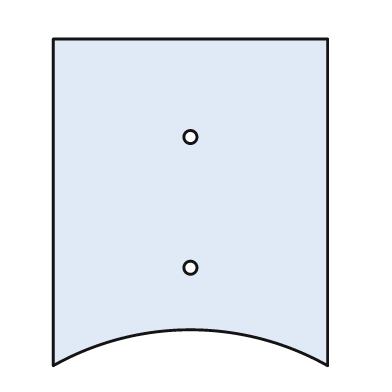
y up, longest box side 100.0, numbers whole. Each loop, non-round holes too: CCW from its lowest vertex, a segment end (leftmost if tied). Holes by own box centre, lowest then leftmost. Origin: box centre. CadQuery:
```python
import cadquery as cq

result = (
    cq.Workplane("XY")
    .moveTo(-42.0, -50.0)
    .threePointArc((0.0, -39.0), (42.0, -50.0))
    .lineTo(42.0, 50.0)
    .lineTo(-42.0, 50.0)
    .close()
    .moveTo(0.0, -20.0)
    .circle(2.0)
    .moveTo(0.0, 20.0)
    .circle(2.0)
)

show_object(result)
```